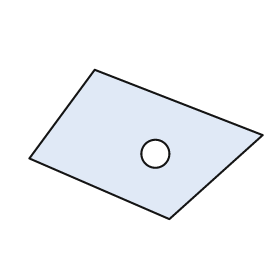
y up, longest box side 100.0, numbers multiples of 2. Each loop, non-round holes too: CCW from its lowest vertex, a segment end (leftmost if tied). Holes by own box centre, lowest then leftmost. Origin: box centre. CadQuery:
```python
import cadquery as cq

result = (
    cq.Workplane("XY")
    .moveTo(10.0, -32.0)
    .lineTo(50.0, 4.0)
    .lineTo(-22.0, 32.0)
    .lineTo(-50.0, -6.0)
    .close()
    .moveTo(4.0, -4.0)
    .circle(6.0)
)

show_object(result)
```